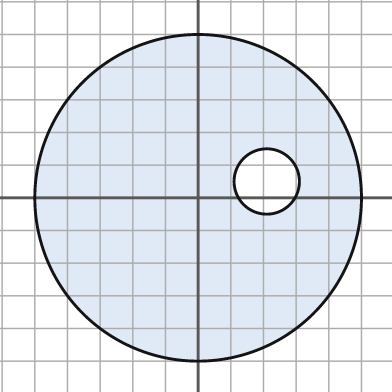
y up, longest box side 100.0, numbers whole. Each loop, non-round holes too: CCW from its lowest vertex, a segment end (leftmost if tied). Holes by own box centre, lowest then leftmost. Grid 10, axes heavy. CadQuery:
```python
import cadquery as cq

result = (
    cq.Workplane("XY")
    .moveTo(0.0, 0.0)
    .circle(50.0)
    .moveTo(21.0, 5.0)
    .circle(10.0)
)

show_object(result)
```